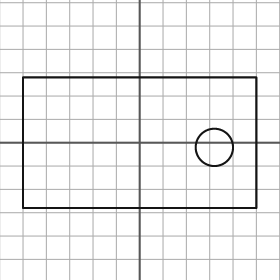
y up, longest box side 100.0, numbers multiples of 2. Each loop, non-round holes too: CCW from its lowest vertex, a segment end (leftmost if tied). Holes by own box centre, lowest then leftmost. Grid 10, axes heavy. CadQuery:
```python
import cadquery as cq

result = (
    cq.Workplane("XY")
    .moveTo(-50.0, -28.0)
    .lineTo(50.0, -28.0)
    .lineTo(50.0, 28.0)
    .lineTo(-50.0, 28.0)
    .close()
    .moveTo(32.0, -2.0)
    .circle(8.0)
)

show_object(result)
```